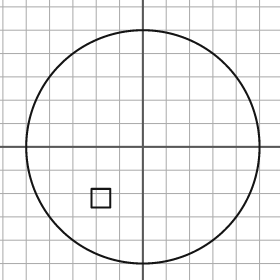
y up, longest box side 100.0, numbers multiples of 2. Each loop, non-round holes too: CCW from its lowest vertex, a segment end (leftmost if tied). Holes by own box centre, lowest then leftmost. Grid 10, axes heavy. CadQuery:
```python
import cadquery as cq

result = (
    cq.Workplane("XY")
    .moveTo(0.0, 0.0)
    .circle(50.0)
    .moveTo(-22.0, -26.0)
    .lineTo(-14.0, -26.0)
    .lineTo(-14.0, -18.0)
    .lineTo(-22.0, -18.0)
    .close()
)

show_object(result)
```